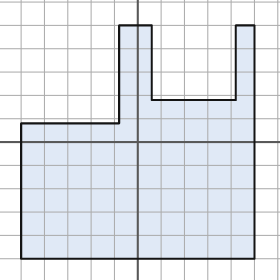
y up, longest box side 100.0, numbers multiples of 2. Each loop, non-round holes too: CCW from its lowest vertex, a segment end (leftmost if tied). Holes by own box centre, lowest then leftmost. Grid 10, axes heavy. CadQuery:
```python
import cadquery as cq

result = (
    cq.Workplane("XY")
    .moveTo(-50.0, -50.0)
    .lineTo(50.0, -50.0)
    .lineTo(50.0, 50.0)
    .lineTo(42.0, 50.0)
    .lineTo(42.0, 18.0)
    .lineTo(6.0, 18.0)
    .lineTo(6.0, 50.0)
    .lineTo(-8.0, 50.0)
    .lineTo(-8.0, 8.0)
    .lineTo(-50.0, 8.0)
    .close()
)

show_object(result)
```